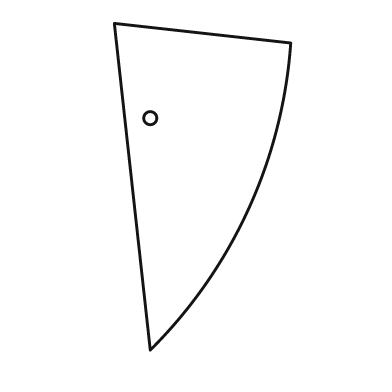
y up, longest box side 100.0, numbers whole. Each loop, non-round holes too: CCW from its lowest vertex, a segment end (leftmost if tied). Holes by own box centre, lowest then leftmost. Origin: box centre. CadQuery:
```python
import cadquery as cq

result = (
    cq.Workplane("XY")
    .moveTo(-16.0, -50.0)
    .threePointArc((14.0, -7.0), (27.0, 44.0))
    .lineTo(-27.0, 50.0)
    .close()
    .moveTo(-16.0, 21.0)
    .circle(2.0)
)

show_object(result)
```